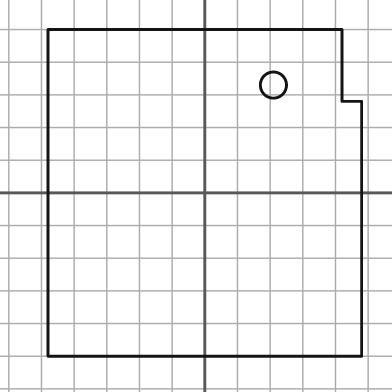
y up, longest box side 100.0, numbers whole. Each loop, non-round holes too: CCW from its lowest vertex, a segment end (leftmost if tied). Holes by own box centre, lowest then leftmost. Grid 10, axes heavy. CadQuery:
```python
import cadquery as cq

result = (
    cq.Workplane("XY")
    .moveTo(-48.0, -50.0)
    .lineTo(48.0, -50.0)
    .lineTo(48.0, 28.0)
    .lineTo(42.0, 28.0)
    .lineTo(42.0, 50.0)
    .lineTo(-48.0, 50.0)
    .close()
    .moveTo(21.0, 33.0)
    .circle(4.0)
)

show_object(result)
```